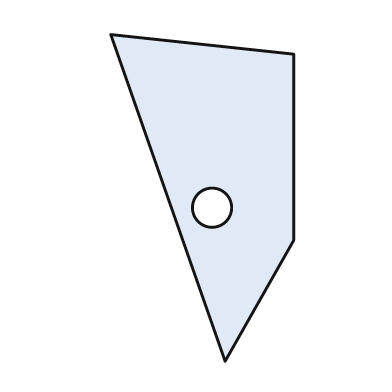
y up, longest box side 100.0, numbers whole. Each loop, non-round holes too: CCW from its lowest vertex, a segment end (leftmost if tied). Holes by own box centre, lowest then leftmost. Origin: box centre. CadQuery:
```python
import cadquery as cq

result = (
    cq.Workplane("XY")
    .moveTo(7.0, -50.0)
    .lineTo(28.0, -13.0)
    .lineTo(28.0, 44.0)
    .lineTo(-28.0, 50.0)
    .close()
    .moveTo(3.0, -3.0)
    .circle(6.0)
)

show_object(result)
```